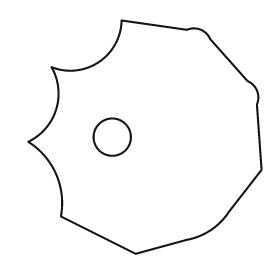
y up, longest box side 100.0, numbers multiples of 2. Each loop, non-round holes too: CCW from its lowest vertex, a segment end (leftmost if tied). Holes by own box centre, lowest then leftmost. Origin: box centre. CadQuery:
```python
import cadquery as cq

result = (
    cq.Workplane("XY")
    .moveTo(-4.0, -50.0)
    .lineTo(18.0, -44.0)
    .threePointArc((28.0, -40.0), (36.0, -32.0))
    .lineTo(50.0, -14.0)
    .lineTo(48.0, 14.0)
    .threePointArc((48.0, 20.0), (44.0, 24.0))
    .lineTo(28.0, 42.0)
    .threePointArc((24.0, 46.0), (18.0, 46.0))
    .lineTo(-10.0, 50.0)
    .threePointArc((-20.0, 32.0), (-40.0, 30.0))
    .threePointArc((-38.0, 12.0), (-50.0, -2.0))
    .threePointArc((-38.0, -16.0), (-36.0, -34.0))
    .close()
    .moveTo(-14.0, 0.0)
    .circle(8.0)
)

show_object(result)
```